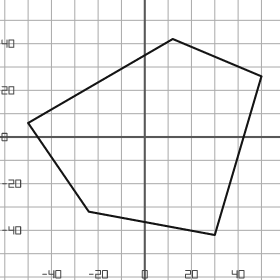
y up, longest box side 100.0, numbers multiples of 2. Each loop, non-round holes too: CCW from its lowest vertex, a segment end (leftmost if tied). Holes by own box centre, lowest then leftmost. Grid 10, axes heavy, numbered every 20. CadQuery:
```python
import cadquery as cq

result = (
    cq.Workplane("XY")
    .moveTo(30.0, -42.0)
    .lineTo(50.0, 26.0)
    .lineTo(12.0, 42.0)
    .lineTo(-50.0, 6.0)
    .lineTo(-24.0, -32.0)
    .close()
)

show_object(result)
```